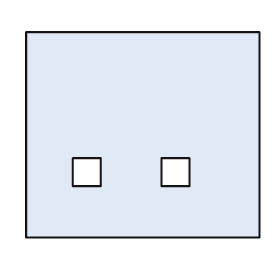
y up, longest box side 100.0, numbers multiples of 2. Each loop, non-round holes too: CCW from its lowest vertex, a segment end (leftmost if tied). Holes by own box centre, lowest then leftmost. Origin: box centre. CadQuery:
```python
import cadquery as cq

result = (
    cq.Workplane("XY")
    .moveTo(-50.0, -44.0)
    .lineTo(50.0, -44.0)
    .lineTo(50.0, 44.0)
    .lineTo(-50.0, 44.0)
    .close()
    .moveTo(-30.0, -22.0)
    .lineTo(-18.0, -22.0)
    .lineTo(-18.0, -10.0)
    .lineTo(-30.0, -10.0)
    .close()
    .moveTo(8.0, -22.0)
    .lineTo(20.0, -22.0)
    .lineTo(20.0, -10.0)
    .lineTo(8.0, -10.0)
    .close()
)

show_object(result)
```